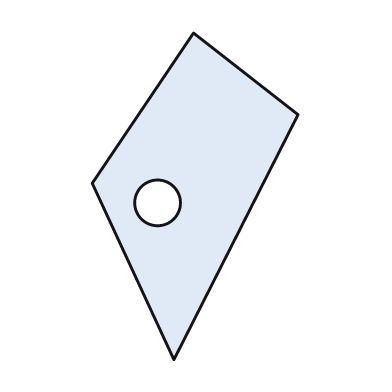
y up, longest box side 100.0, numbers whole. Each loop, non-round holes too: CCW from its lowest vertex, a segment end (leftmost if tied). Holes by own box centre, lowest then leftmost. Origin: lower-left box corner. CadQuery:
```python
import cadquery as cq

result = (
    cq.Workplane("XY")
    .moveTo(25.0, 0.0)
    .lineTo(63.0, 75.0)
    .lineTo(31.0, 100.0)
    .lineTo(0.0, 54.0)
    .close()
    .moveTo(20.0, 48.0)
    .circle(7.0)
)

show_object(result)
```